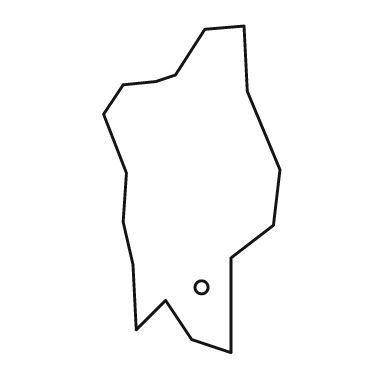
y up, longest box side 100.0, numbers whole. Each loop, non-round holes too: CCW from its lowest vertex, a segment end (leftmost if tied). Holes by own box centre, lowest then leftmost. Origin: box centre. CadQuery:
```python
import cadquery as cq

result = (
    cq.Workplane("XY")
    .moveTo(12.0, -50.0)
    .lineTo(12.0, -21.0)
    .lineTo(25.0, -11.0)
    .lineTo(27.0, 6.0)
    .lineTo(17.0, 30.0)
    .lineTo(16.0, 50.0)
    .lineTo(4.0, 49.0)
    .lineTo(-5.0, 35.0)
    .lineTo(-11.0, 33.0)
    .lineTo(-21.0, 32.0)
    .lineTo(-27.0, 23.0)
    .lineTo(-20.0, 5.0)
    .lineTo(-21.0, -10.0)
    .lineTo(-18.0, -23.0)
    .lineTo(-17.0, -43.0)
    .lineTo(-8.0, -34.0)
    .lineTo(0.0, -46.0)
    .close()
    .moveTo(3.0, -30.0)
    .circle(2.0)
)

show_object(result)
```